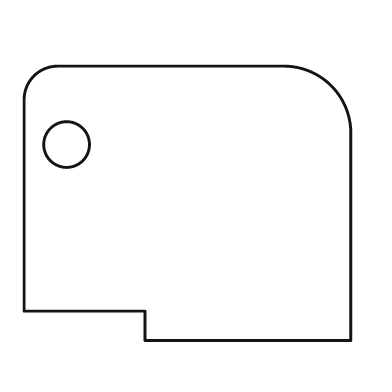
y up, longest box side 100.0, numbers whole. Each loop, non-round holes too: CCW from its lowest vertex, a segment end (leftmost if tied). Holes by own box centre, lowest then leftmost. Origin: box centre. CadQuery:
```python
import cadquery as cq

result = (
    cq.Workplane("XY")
    .moveTo(-13.0, -42.0)
    .lineTo(50.0, -42.0)
    .lineTo(50.0, 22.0)
    .threePointArc((44.0, 36.0), (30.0, 42.0))
    .lineTo(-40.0, 42.0)
    .threePointArc((-47.0, 39.0), (-50.0, 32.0))
    .lineTo(-50.0, -33.0)
    .lineTo(-13.0, -33.0)
    .close()
    .moveTo(-37.0, 18.0)
    .circle(7.0)
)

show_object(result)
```